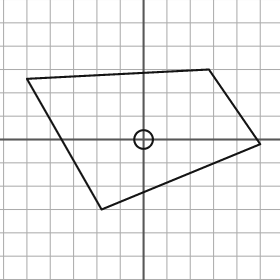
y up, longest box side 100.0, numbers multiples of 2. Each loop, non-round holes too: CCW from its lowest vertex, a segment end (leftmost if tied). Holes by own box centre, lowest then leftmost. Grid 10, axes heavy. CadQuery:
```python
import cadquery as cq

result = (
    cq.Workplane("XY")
    .moveTo(-18.0, -30.0)
    .lineTo(50.0, -2.0)
    .lineTo(28.0, 30.0)
    .lineTo(-50.0, 26.0)
    .close()
    .moveTo(0.0, 0.0)
    .circle(4.0)
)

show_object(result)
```